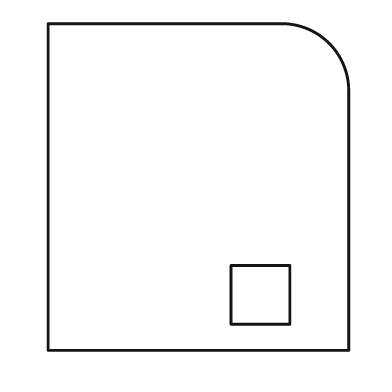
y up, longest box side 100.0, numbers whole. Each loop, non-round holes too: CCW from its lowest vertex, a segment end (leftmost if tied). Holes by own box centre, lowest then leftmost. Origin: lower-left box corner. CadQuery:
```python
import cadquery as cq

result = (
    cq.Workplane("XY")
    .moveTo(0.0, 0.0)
    .lineTo(92.0, 0.0)
    .lineTo(92.0, 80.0)
    .threePointArc((86.0, 94.0), (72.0, 100.0))
    .lineTo(0.0, 100.0)
    .close()
    .moveTo(56.0, 8.0)
    .lineTo(74.0, 8.0)
    .lineTo(74.0, 26.0)
    .lineTo(56.0, 26.0)
    .close()
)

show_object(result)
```